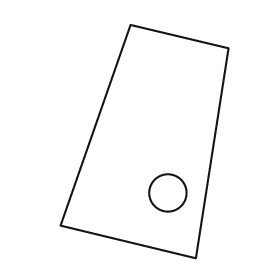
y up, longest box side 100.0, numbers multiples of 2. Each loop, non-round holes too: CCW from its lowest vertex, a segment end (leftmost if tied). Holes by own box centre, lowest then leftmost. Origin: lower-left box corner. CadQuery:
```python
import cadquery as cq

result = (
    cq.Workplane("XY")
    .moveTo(58.0, 0.0)
    .lineTo(72.0, 90.0)
    .lineTo(30.0, 100.0)
    .lineTo(0.0, 14.0)
    .close()
    .moveTo(46.0, 28.0)
    .circle(8.0)
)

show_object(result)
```